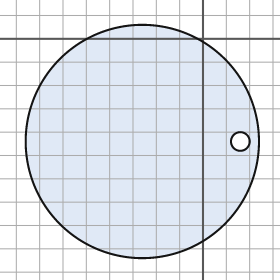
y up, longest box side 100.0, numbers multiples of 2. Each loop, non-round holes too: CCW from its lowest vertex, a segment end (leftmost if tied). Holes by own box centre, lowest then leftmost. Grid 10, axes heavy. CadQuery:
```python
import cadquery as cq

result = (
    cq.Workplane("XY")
    .moveTo(-26.0, -44.0)
    .circle(50.0)
    .moveTo(16.0, -44.0)
    .circle(4.0)
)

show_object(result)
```